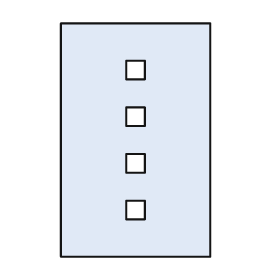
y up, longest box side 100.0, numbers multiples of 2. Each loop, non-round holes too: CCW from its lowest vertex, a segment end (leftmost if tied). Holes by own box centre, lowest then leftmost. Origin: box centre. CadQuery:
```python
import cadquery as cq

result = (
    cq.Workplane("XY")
    .moveTo(-32.0, -50.0)
    .lineTo(32.0, -50.0)
    .lineTo(32.0, 50.0)
    .lineTo(-32.0, 50.0)
    .close()
    .moveTo(-4.0, -34.0)
    .lineTo(4.0, -34.0)
    .lineTo(4.0, -26.0)
    .lineTo(-4.0, -26.0)
    .close()
    .moveTo(-4.0, -14.0)
    .lineTo(4.0, -14.0)
    .lineTo(4.0, -6.0)
    .lineTo(-4.0, -6.0)
    .close()
    .moveTo(-4.0, 6.0)
    .lineTo(4.0, 6.0)
    .lineTo(4.0, 14.0)
    .lineTo(-4.0, 14.0)
    .close()
    .moveTo(-4.0, 26.0)
    .lineTo(4.0, 26.0)
    .lineTo(4.0, 34.0)
    .lineTo(-4.0, 34.0)
    .close()
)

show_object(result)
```